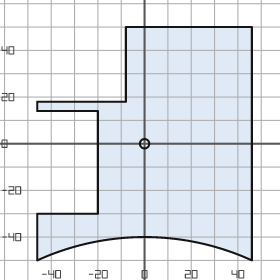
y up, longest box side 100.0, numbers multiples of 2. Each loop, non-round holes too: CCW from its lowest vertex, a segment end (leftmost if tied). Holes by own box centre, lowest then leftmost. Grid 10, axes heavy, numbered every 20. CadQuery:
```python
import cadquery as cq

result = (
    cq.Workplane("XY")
    .moveTo(-46.0, -50.0)
    .threePointArc((0.0, -40.0), (46.0, -50.0))
    .lineTo(46.0, 50.0)
    .lineTo(-8.0, 50.0)
    .lineTo(-8.0, 18.0)
    .lineTo(-46.0, 18.0)
    .lineTo(-46.0, 14.0)
    .lineTo(-20.0, 14.0)
    .lineTo(-20.0, -30.0)
    .lineTo(-46.0, -30.0)
    .close()
    .moveTo(0.0, 0.0)
    .circle(2.0)
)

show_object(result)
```